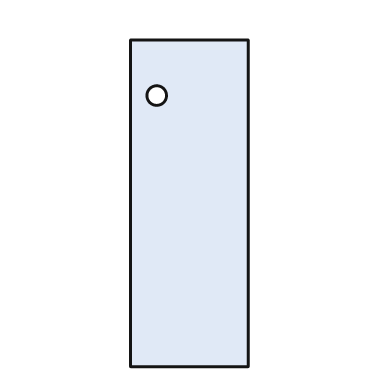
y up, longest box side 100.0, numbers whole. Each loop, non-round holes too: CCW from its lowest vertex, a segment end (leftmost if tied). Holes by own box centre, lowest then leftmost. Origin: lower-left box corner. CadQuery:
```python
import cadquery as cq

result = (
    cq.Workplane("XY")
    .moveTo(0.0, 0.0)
    .lineTo(36.0, 0.0)
    .lineTo(36.0, 100.0)
    .lineTo(0.0, 100.0)
    .close()
    .moveTo(8.0, 83.0)
    .circle(3.0)
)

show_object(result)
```